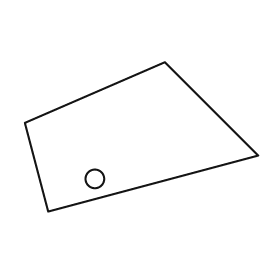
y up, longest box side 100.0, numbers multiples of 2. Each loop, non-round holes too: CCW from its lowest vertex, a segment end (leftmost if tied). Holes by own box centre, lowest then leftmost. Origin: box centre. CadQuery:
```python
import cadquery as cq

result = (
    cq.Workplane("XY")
    .moveTo(-40.0, -32.0)
    .lineTo(50.0, -8.0)
    .lineTo(10.0, 32.0)
    .lineTo(-50.0, 6.0)
    .close()
    .moveTo(-20.0, -18.0)
    .circle(4.0)
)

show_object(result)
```